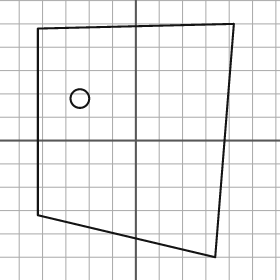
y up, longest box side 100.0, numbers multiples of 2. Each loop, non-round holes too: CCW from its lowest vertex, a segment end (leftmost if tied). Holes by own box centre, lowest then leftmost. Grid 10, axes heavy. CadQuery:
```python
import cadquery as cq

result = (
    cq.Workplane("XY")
    .moveTo(34.0, -50.0)
    .lineTo(42.0, 50.0)
    .lineTo(-42.0, 48.0)
    .lineTo(-42.0, -32.0)
    .close()
    .moveTo(-24.0, 18.0)
    .circle(4.0)
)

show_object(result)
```